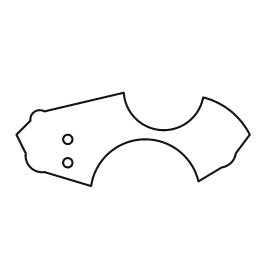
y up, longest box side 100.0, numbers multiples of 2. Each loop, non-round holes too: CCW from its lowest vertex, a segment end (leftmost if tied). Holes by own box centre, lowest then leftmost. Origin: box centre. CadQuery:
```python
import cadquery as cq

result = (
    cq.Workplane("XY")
    .moveTo(-18.0, -20.0)
    .threePointArc((4.0, 0.0), (28.0, -18.0))
    .lineTo(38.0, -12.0)
    .threePointArc((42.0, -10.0), (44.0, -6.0))
    .lineTo(50.0, 2.0)
    .threePointArc((42.0, 12.0), (30.0, 18.0))
    .threePointArc((12.0, 4.0), (-4.0, 20.0))
    .lineTo(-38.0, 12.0)
    .threePointArc((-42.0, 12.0), (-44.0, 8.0))
    .lineTo(-50.0, 2.0)
    .lineTo(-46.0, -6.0)
    .threePointArc((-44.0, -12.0), (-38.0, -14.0))
    .close()
    .moveTo(-28.0, -10.0)
    .circle(2.0)
    .moveTo(-28.0, 0.0)
    .circle(2.0)
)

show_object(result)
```